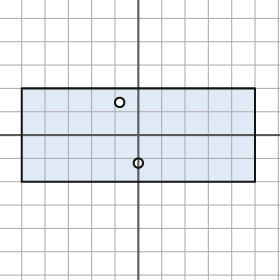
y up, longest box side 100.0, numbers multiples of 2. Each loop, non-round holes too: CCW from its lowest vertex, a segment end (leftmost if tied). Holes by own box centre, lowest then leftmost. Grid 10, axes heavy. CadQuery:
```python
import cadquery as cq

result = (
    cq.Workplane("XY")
    .moveTo(-50.0, -20.0)
    .lineTo(50.0, -20.0)
    .lineTo(50.0, 20.0)
    .lineTo(-50.0, 20.0)
    .close()
    .moveTo(0.0, -12.0)
    .circle(2.0)
    .moveTo(-8.0, 14.0)
    .circle(2.0)
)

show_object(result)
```